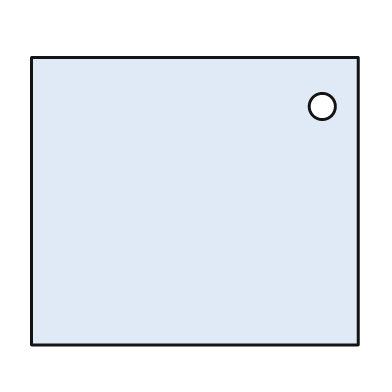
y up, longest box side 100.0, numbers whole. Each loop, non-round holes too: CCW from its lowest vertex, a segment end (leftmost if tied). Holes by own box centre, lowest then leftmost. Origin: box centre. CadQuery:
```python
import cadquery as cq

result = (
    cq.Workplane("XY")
    .moveTo(-50.0, -44.0)
    .lineTo(50.0, -44.0)
    .lineTo(50.0, 44.0)
    .lineTo(-50.0, 44.0)
    .close()
    .moveTo(39.0, 29.0)
    .circle(4.0)
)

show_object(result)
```